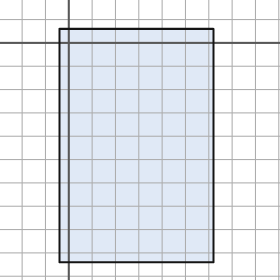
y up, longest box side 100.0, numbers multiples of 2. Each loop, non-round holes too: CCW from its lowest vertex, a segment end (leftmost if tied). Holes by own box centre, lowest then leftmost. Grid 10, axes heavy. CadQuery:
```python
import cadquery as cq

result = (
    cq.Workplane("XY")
    .moveTo(-4.0, -94.0)
    .lineTo(62.0, -94.0)
    .lineTo(62.0, 6.0)
    .lineTo(-4.0, 6.0)
    .close()
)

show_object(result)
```